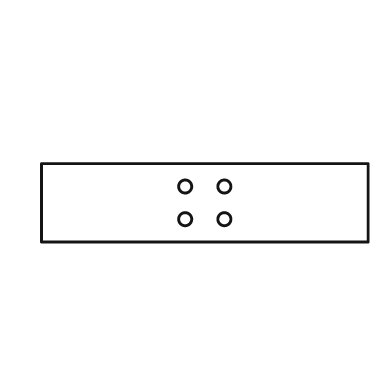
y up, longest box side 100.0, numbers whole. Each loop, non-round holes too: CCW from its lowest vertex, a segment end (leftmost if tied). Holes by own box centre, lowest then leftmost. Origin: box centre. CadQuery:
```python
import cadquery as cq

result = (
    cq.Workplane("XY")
    .moveTo(-50.0, -12.0)
    .lineTo(50.0, -12.0)
    .lineTo(50.0, 12.0)
    .lineTo(-50.0, 12.0)
    .close()
    .moveTo(-6.0, -5.0)
    .circle(2.0)
    .moveTo(6.0, -5.0)
    .circle(2.0)
    .moveTo(-6.0, 5.0)
    .circle(2.0)
    .moveTo(6.0, 5.0)
    .circle(2.0)
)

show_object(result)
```